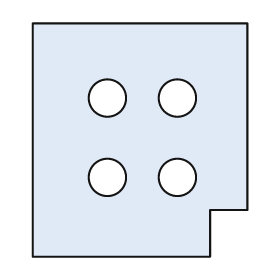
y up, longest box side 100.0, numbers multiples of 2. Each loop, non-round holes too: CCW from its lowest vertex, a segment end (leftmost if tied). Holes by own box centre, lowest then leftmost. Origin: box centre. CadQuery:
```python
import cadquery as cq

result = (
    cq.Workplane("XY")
    .moveTo(-46.0, -50.0)
    .lineTo(30.0, -50.0)
    .lineTo(30.0, -30.0)
    .lineTo(46.0, -30.0)
    .lineTo(46.0, 50.0)
    .lineTo(-46.0, 50.0)
    .close()
    .moveTo(-14.0, -16.0)
    .circle(8.0)
    .moveTo(16.0, -16.0)
    .circle(8.0)
    .moveTo(-14.0, 18.0)
    .circle(8.0)
    .moveTo(16.0, 18.0)
    .circle(8.0)
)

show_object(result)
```